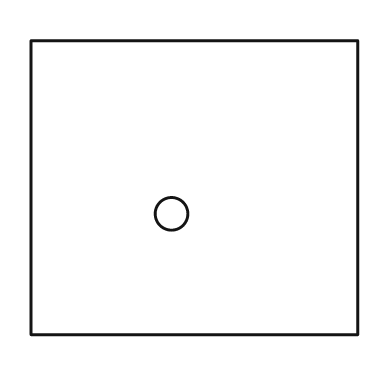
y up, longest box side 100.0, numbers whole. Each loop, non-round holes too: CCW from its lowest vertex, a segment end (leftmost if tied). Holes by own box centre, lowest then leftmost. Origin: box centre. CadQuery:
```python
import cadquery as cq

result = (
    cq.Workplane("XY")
    .moveTo(-50.0, -45.0)
    .lineTo(50.0, -45.0)
    .lineTo(50.0, 45.0)
    .lineTo(-50.0, 45.0)
    .close()
    .moveTo(-7.0, -8.0)
    .circle(5.0)
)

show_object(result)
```